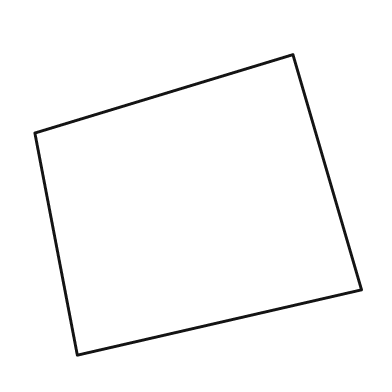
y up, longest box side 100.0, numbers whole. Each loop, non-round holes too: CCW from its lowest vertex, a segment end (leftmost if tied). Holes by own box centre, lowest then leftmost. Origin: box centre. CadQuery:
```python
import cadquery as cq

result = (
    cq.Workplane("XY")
    .moveTo(-37.0, -46.0)
    .lineTo(50.0, -26.0)
    .lineTo(29.0, 46.0)
    .lineTo(-50.0, 22.0)
    .close()
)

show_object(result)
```